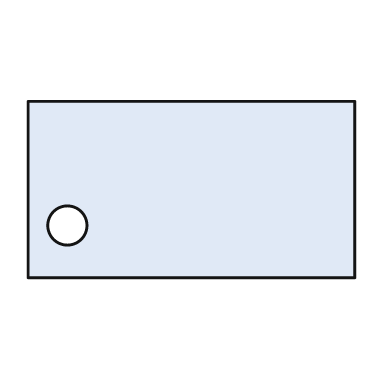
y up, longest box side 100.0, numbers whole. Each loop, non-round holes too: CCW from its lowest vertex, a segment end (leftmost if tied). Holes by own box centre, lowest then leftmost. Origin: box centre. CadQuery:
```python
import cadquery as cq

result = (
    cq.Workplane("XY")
    .moveTo(-50.0, -27.0)
    .lineTo(50.0, -27.0)
    .lineTo(50.0, 27.0)
    .lineTo(-50.0, 27.0)
    .close()
    .moveTo(-38.0, -11.0)
    .circle(6.0)
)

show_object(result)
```